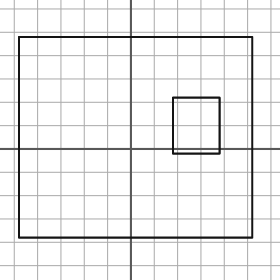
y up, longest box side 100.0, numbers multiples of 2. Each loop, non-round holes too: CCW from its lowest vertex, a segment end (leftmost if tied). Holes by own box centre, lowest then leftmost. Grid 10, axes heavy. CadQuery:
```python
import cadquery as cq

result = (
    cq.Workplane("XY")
    .moveTo(-48.0, -38.0)
    .lineTo(52.0, -38.0)
    .lineTo(52.0, 48.0)
    .lineTo(-48.0, 48.0)
    .close()
    .moveTo(18.0, -2.0)
    .lineTo(38.0, -2.0)
    .lineTo(38.0, 22.0)
    .lineTo(18.0, 22.0)
    .close()
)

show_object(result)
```